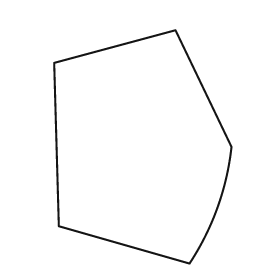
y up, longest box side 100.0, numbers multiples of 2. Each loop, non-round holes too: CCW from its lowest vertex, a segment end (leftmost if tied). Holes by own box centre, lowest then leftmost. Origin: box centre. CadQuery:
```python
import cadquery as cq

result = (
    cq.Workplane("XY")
    .moveTo(20.0, -50.0)
    .threePointArc((32.0, -26.0), (38.0, 0.0))
    .lineTo(14.0, 50.0)
    .lineTo(-38.0, 36.0)
    .lineTo(-36.0, -34.0)
    .close()
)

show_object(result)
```